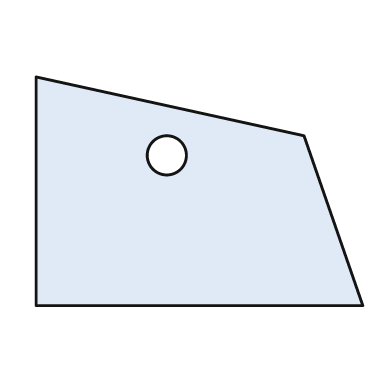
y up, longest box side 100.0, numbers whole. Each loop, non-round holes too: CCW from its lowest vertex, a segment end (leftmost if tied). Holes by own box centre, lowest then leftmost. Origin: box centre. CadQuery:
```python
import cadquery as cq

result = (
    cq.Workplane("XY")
    .moveTo(-50.0, -35.0)
    .lineTo(50.0, -35.0)
    .lineTo(32.0, 17.0)
    .lineTo(-50.0, 35.0)
    .close()
    .moveTo(-10.0, 11.0)
    .circle(6.0)
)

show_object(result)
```